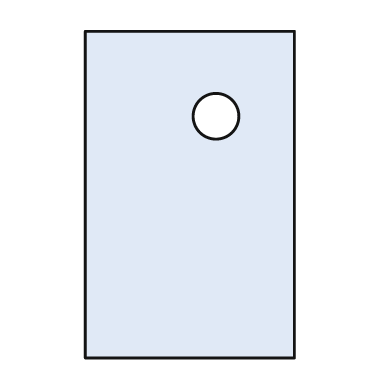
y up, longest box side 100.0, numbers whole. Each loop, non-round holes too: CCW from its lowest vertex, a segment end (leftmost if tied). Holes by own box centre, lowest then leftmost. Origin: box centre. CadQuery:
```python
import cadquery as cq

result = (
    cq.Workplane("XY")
    .moveTo(-32.0, -50.0)
    .lineTo(32.0, -50.0)
    .lineTo(32.0, 50.0)
    .lineTo(-32.0, 50.0)
    .close()
    .moveTo(8.0, 24.0)
    .circle(7.0)
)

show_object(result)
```